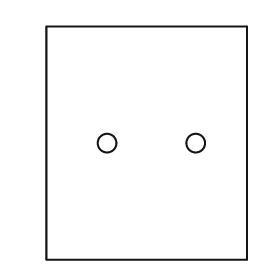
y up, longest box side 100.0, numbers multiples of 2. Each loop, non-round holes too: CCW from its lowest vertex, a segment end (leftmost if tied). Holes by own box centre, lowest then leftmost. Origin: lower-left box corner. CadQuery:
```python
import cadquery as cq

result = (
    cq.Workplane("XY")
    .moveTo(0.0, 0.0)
    .lineTo(86.0, 0.0)
    .lineTo(86.0, 100.0)
    .lineTo(0.0, 100.0)
    .close()
    .moveTo(26.0, 50.0)
    .circle(4.0)
    .moveTo(64.0, 50.0)
    .circle(4.0)
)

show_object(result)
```